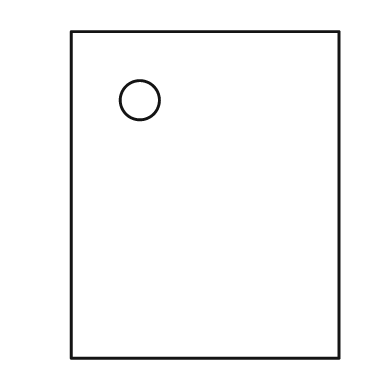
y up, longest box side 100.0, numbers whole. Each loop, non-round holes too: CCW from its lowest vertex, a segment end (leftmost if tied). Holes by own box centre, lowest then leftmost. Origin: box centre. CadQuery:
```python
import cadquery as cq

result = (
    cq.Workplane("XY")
    .moveTo(-41.0, -50.0)
    .lineTo(41.0, -50.0)
    .lineTo(41.0, 50.0)
    .lineTo(-41.0, 50.0)
    .close()
    .moveTo(-20.0, 29.0)
    .circle(6.0)
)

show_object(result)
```